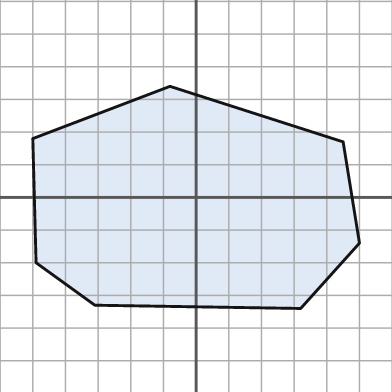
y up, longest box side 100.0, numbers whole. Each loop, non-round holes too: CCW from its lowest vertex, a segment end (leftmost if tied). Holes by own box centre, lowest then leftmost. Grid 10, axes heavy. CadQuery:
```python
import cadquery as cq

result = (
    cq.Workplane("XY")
    .moveTo(32.0, -34.0)
    .lineTo(50.0, -14.0)
    .lineTo(45.0, 17.0)
    .lineTo(-8.0, 34.0)
    .lineTo(-50.0, 18.0)
    .lineTo(-49.0, -20.0)
    .lineTo(-31.0, -33.0)
    .close()
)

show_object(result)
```